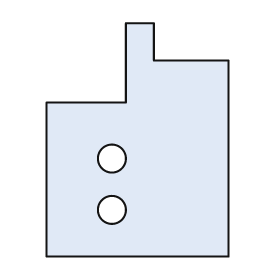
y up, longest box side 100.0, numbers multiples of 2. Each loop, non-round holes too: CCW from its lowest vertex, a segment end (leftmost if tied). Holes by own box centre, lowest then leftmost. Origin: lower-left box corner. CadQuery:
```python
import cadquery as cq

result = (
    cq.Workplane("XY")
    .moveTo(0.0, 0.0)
    .lineTo(78.0, 0.0)
    .lineTo(78.0, 84.0)
    .lineTo(46.0, 84.0)
    .lineTo(46.0, 100.0)
    .lineTo(34.0, 100.0)
    .lineTo(34.0, 66.0)
    .lineTo(0.0, 66.0)
    .close()
    .moveTo(28.0, 20.0)
    .circle(6.0)
    .moveTo(28.0, 42.0)
    .circle(6.0)
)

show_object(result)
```